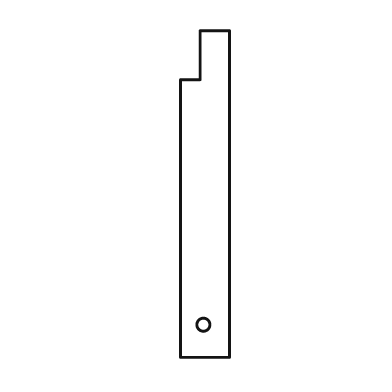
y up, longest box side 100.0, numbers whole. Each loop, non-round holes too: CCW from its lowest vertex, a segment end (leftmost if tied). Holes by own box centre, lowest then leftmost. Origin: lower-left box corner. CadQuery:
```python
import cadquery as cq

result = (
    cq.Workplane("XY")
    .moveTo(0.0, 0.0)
    .lineTo(15.0, 0.0)
    .lineTo(15.0, 100.0)
    .lineTo(6.0, 100.0)
    .lineTo(6.0, 85.0)
    .lineTo(0.0, 85.0)
    .close()
    .moveTo(7.0, 10.0)
    .circle(2.0)
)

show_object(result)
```